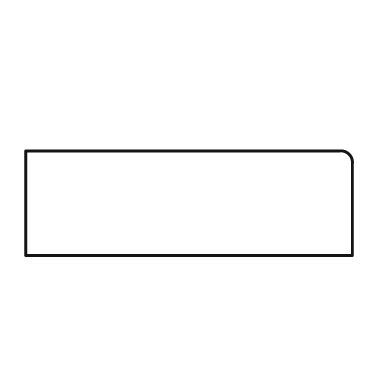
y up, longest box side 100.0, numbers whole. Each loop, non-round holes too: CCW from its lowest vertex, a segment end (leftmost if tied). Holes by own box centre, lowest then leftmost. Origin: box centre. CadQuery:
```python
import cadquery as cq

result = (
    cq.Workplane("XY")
    .moveTo(-50.0, -16.0)
    .lineTo(50.0, -16.0)
    .lineTo(50.0, 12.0)
    .threePointArc((49.0, 15.0), (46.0, 16.0))
    .lineTo(-50.0, 16.0)
    .close()
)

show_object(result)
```